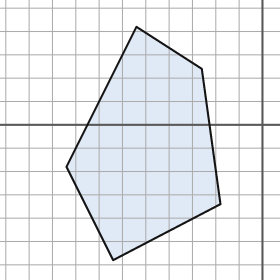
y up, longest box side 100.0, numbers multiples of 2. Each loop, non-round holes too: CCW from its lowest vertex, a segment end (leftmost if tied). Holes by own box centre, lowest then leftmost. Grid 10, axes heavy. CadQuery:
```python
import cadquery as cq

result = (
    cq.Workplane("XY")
    .moveTo(-64.0, -58.0)
    .lineTo(-18.0, -34.0)
    .lineTo(-26.0, 24.0)
    .lineTo(-54.0, 42.0)
    .lineTo(-84.0, -18.0)
    .close()
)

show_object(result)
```